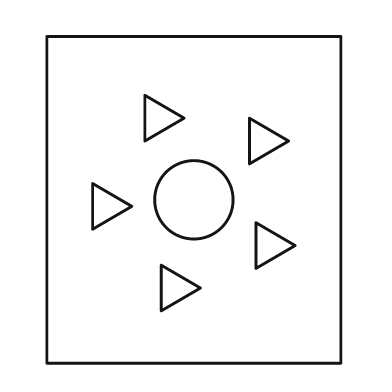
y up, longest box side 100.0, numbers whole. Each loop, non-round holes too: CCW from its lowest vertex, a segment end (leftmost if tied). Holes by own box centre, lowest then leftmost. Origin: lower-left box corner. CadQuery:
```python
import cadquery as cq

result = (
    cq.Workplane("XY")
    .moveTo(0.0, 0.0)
    .lineTo(90.0, 0.0)
    .lineTo(90.0, 100.0)
    .lineTo(0.0, 100.0)
    .close()
    .moveTo(35.0, 16.0)
    .lineTo(47.0, 23.0)
    .lineTo(35.0, 30.0)
    .close()
    .moveTo(64.0, 29.0)
    .lineTo(76.0, 36.0)
    .lineTo(64.0, 43.0)
    .close()
    .moveTo(14.0, 41.0)
    .lineTo(26.0, 48.0)
    .lineTo(14.0, 55.0)
    .close()
    .moveTo(45.0, 50.0)
    .circle(12.0)
    .moveTo(62.0, 61.0)
    .lineTo(74.0, 68.0)
    .lineTo(62.0, 75.0)
    .close()
    .moveTo(30.0, 68.0)
    .lineTo(42.0, 75.0)
    .lineTo(30.0, 82.0)
    .close()
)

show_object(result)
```